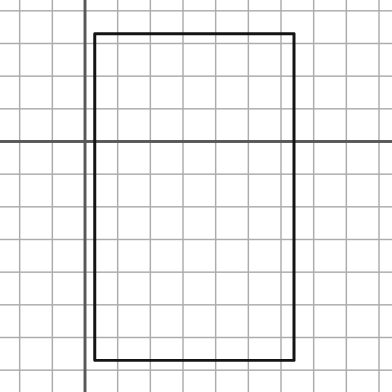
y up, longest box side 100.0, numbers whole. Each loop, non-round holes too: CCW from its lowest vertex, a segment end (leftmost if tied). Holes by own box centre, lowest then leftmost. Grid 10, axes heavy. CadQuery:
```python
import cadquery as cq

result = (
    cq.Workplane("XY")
    .moveTo(3.0, -67.0)
    .lineTo(64.0, -67.0)
    .lineTo(64.0, 33.0)
    .lineTo(3.0, 33.0)
    .close()
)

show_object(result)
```